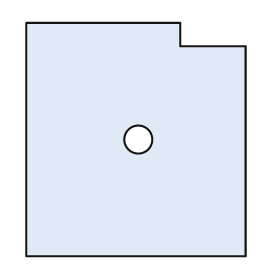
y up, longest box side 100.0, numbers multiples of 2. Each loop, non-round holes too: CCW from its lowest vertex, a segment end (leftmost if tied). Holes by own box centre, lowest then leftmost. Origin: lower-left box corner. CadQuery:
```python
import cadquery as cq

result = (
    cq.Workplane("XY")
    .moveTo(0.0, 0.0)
    .lineTo(94.0, 0.0)
    .lineTo(94.0, 90.0)
    .lineTo(66.0, 90.0)
    .lineTo(66.0, 100.0)
    .lineTo(0.0, 100.0)
    .close()
    .moveTo(48.0, 50.0)
    .circle(6.0)
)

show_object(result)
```